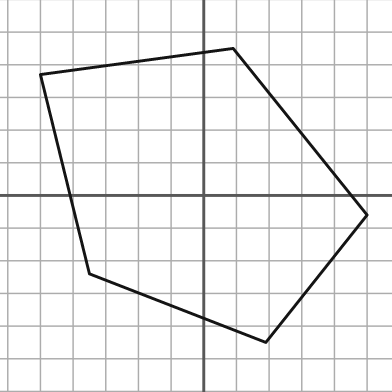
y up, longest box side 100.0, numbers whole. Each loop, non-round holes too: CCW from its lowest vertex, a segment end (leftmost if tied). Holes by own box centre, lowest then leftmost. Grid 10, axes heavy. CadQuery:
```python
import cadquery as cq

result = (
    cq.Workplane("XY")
    .moveTo(19.0, -45.0)
    .lineTo(50.0, -6.0)
    .lineTo(9.0, 45.0)
    .lineTo(-50.0, 37.0)
    .lineTo(-35.0, -24.0)
    .close()
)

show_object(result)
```